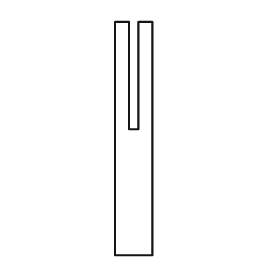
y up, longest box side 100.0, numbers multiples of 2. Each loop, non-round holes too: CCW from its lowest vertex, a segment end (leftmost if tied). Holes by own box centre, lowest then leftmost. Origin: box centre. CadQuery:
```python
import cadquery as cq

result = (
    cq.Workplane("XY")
    .moveTo(-8.0, -50.0)
    .lineTo(8.0, -50.0)
    .lineTo(8.0, 50.0)
    .lineTo(2.0, 50.0)
    .lineTo(2.0, 4.0)
    .lineTo(-2.0, 4.0)
    .lineTo(-2.0, 50.0)
    .lineTo(-8.0, 50.0)
    .close()
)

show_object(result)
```